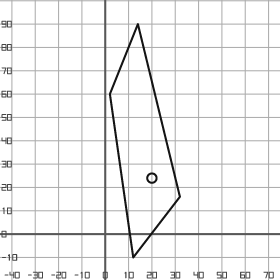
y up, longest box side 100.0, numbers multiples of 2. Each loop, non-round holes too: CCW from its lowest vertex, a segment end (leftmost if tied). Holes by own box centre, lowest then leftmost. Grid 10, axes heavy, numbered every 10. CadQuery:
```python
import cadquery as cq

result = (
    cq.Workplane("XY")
    .moveTo(12.0, -10.0)
    .lineTo(32.0, 16.0)
    .lineTo(14.0, 90.0)
    .lineTo(2.0, 60.0)
    .close()
    .moveTo(20.0, 24.0)
    .circle(2.0)
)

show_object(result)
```